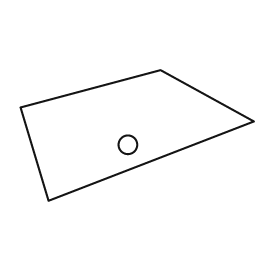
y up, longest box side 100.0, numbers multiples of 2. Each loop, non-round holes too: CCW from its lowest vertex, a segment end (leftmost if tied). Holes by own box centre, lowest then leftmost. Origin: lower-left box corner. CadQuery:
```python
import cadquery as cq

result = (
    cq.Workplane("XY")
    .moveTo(12.0, 0.0)
    .lineTo(100.0, 34.0)
    .lineTo(60.0, 56.0)
    .lineTo(0.0, 40.0)
    .close()
    .moveTo(46.0, 24.0)
    .circle(4.0)
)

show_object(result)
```